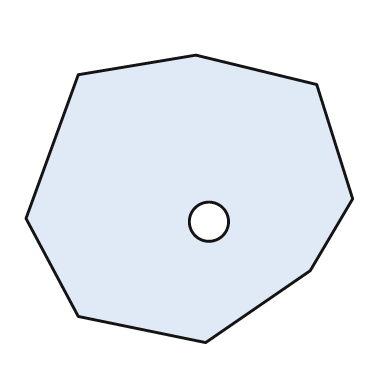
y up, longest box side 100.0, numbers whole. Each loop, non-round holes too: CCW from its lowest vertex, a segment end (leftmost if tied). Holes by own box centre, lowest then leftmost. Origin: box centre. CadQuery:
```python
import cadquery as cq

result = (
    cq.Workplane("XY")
    .moveTo(5.0, -44.0)
    .lineTo(37.0, -22.0)
    .lineTo(50.0, 0.0)
    .lineTo(39.0, 35.0)
    .lineTo(2.0, 44.0)
    .lineTo(-34.0, 38.0)
    .lineTo(-50.0, -6.0)
    .lineTo(-34.0, -36.0)
    .close()
    .moveTo(6.0, -7.0)
    .circle(6.0)
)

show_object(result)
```